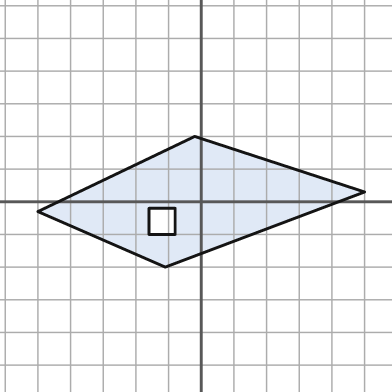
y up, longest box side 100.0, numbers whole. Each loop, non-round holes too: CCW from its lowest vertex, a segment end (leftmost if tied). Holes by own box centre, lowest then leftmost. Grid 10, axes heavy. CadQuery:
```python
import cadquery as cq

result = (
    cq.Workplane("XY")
    .moveTo(-11.0, -20.0)
    .lineTo(50.0, 3.0)
    .lineTo(-2.0, 20.0)
    .lineTo(-50.0, -3.0)
    .close()
    .moveTo(-16.0, -10.0)
    .lineTo(-8.0, -10.0)
    .lineTo(-8.0, -2.0)
    .lineTo(-16.0, -2.0)
    .close()
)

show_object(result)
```